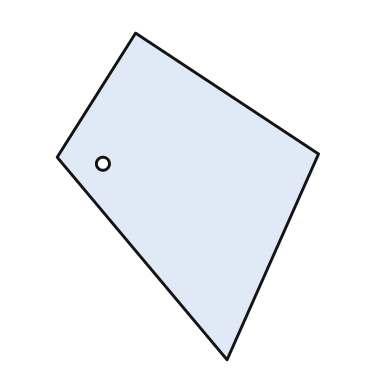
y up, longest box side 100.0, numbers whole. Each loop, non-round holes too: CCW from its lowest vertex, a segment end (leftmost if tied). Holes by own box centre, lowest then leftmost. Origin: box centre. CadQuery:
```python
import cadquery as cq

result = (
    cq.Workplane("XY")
    .moveTo(12.0, -50.0)
    .lineTo(40.0, 13.0)
    .lineTo(-16.0, 50.0)
    .lineTo(-40.0, 12.0)
    .close()
    .moveTo(-26.0, 10.0)
    .circle(2.0)
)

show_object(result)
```